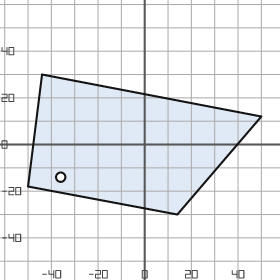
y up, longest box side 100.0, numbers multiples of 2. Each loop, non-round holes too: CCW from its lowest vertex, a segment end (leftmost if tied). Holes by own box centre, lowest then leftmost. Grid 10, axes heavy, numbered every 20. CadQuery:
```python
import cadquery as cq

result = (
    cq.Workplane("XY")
    .moveTo(14.0, -30.0)
    .lineTo(50.0, 12.0)
    .lineTo(-44.0, 30.0)
    .lineTo(-50.0, -18.0)
    .close()
    .moveTo(-36.0, -14.0)
    .circle(2.0)
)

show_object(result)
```